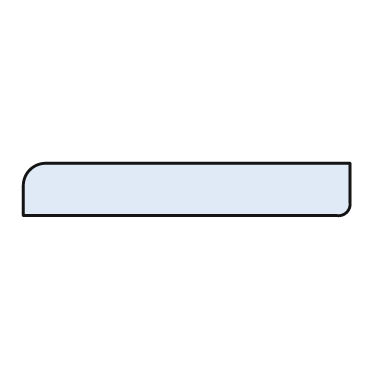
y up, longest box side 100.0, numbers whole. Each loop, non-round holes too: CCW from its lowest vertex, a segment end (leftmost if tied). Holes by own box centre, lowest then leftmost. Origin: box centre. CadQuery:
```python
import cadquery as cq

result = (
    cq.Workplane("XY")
    .moveTo(-50.0, -8.0)
    .lineTo(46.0, -8.0)
    .threePointArc((49.0, -7.0), (50.0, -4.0))
    .lineTo(50.0, 8.0)
    .lineTo(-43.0, 8.0)
    .threePointArc((-48.0, 6.0), (-50.0, 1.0))
    .close()
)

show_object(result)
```